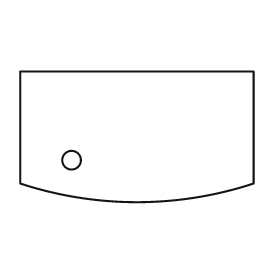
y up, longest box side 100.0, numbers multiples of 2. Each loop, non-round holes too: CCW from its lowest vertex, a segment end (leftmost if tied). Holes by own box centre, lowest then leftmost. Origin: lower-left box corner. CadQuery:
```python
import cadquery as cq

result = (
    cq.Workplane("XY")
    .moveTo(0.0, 8.0)
    .threePointArc((50.0, 0.0), (100.0, 8.0))
    .lineTo(100.0, 56.0)
    .lineTo(0.0, 56.0)
    .close()
    .moveTo(22.0, 18.0)
    .circle(4.0)
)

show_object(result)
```